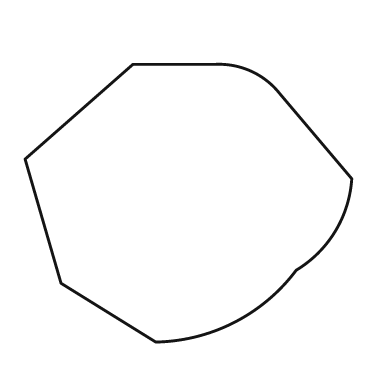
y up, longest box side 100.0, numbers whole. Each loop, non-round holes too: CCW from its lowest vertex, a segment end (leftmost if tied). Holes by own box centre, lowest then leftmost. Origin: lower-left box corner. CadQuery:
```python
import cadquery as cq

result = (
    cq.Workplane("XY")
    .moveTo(40.0, 0.0)
    .threePointArc((64.0, 6.0), (83.0, 22.0))
    .threePointArc((95.0, 34.0), (100.0, 50.0))
    .lineTo(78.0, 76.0)
    .threePointArc((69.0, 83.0), (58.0, 85.0))
    .lineTo(33.0, 85.0)
    .lineTo(0.0, 56.0)
    .lineTo(11.0, 18.0)
    .close()
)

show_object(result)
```